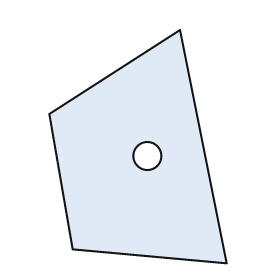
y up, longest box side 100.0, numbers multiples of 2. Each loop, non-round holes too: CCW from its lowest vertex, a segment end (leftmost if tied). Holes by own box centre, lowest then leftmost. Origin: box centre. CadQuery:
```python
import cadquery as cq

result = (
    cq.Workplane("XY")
    .moveTo(38.0, -50.0)
    .lineTo(18.0, 50.0)
    .lineTo(-38.0, 14.0)
    .lineTo(-28.0, -44.0)
    .close()
    .moveTo(4.0, -4.0)
    .circle(6.0)
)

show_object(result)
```